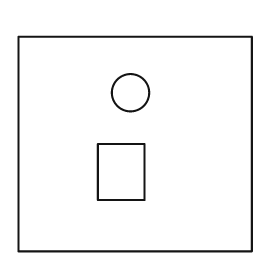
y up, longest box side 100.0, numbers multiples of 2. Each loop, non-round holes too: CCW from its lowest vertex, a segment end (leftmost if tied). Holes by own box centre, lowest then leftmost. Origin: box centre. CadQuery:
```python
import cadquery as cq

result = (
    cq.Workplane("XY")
    .moveTo(-50.0, -46.0)
    .lineTo(50.0, -46.0)
    .lineTo(50.0, 46.0)
    .lineTo(-50.0, 46.0)
    .close()
    .moveTo(-16.0, -24.0)
    .lineTo(4.0, -24.0)
    .lineTo(4.0, 0.0)
    .lineTo(-16.0, 0.0)
    .close()
    .moveTo(-2.0, 22.0)
    .circle(8.0)
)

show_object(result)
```